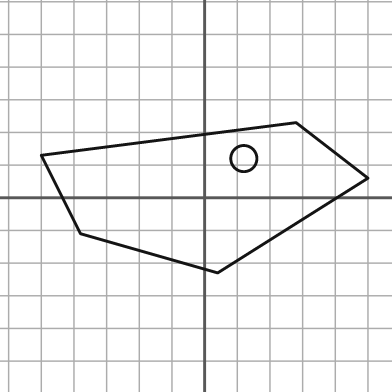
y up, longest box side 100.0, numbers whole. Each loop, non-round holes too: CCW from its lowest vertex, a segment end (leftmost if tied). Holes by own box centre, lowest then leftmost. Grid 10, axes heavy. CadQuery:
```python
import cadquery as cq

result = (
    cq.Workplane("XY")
    .moveTo(4.0, -23.0)
    .lineTo(50.0, 6.0)
    .lineTo(28.0, 23.0)
    .lineTo(-50.0, 13.0)
    .lineTo(-38.0, -11.0)
    .close()
    .moveTo(12.0, 12.0)
    .circle(4.0)
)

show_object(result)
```